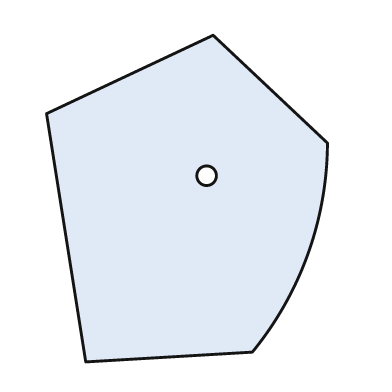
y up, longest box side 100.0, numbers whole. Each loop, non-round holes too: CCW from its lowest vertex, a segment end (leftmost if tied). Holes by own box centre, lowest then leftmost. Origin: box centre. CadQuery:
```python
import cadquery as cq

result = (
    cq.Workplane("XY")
    .moveTo(-31.0, -50.0)
    .lineTo(20.0, -47.0)
    .threePointArc((37.0, -17.0), (43.0, 17.0))
    .lineTo(8.0, 50.0)
    .lineTo(-43.0, 26.0)
    .close()
    .moveTo(6.0, 7.0)
    .circle(3.0)
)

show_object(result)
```